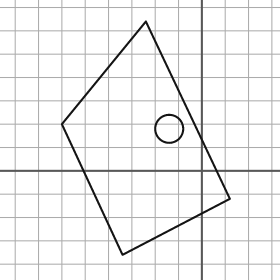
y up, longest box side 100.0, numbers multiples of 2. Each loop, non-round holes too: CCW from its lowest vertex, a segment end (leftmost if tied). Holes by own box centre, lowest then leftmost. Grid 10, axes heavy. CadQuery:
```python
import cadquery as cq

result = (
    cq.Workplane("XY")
    .moveTo(-34.0, -36.0)
    .lineTo(12.0, -12.0)
    .lineTo(-24.0, 64.0)
    .lineTo(-60.0, 20.0)
    .close()
    .moveTo(-14.0, 18.0)
    .circle(6.0)
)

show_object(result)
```